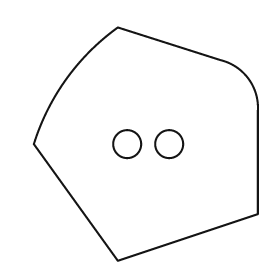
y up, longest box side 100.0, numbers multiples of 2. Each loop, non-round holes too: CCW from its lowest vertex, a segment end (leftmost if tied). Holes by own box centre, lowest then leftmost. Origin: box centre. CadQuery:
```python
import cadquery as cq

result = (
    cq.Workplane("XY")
    .moveTo(-12.0, -50.0)
    .lineTo(48.0, -30.0)
    .lineTo(48.0, 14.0)
    .threePointArc((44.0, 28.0), (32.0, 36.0))
    .lineTo(-12.0, 50.0)
    .threePointArc((-34.0, 28.0), (-48.0, 0.0))
    .close()
    .moveTo(-8.0, 0.0)
    .circle(6.0)
    .moveTo(10.0, 0.0)
    .circle(6.0)
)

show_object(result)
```